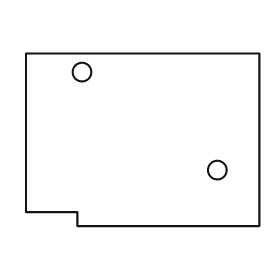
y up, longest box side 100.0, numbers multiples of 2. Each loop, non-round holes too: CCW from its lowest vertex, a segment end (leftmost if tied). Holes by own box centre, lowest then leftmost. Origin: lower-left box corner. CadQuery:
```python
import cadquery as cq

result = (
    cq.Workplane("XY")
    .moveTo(22.0, 0.0)
    .lineTo(100.0, 0.0)
    .lineTo(100.0, 74.0)
    .lineTo(0.0, 74.0)
    .lineTo(0.0, 6.0)
    .lineTo(22.0, 6.0)
    .close()
    .moveTo(82.0, 24.0)
    .circle(4.0)
    .moveTo(24.0, 66.0)
    .circle(4.0)
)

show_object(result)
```